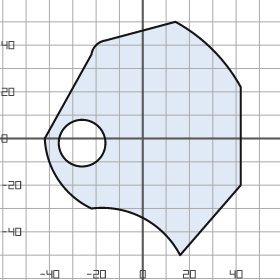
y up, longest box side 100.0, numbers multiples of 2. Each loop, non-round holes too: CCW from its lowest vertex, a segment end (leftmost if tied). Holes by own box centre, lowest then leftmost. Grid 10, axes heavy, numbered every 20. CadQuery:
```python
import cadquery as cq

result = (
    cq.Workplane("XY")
    .moveTo(16.0, -50.0)
    .lineTo(42.0, -20.0)
    .lineTo(42.0, 22.0)
    .threePointArc((30.0, 38.0), (14.0, 50.0))
    .lineTo(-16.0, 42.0)
    .threePointArc((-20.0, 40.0), (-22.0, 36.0))
    .lineTo(-42.0, 0.0)
    .threePointArc((-36.0, -18.0), (-22.0, -30.0))
    .threePointArc((0.0, -34.0), (16.0, -50.0))
    .close()
    .moveTo(-26.0, -2.0)
    .circle(10.0)
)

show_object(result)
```